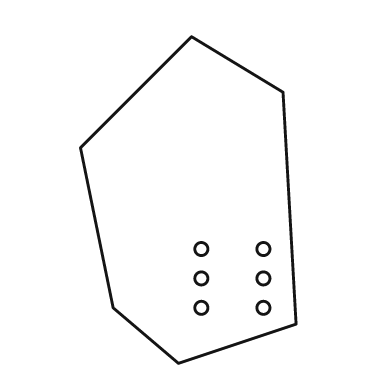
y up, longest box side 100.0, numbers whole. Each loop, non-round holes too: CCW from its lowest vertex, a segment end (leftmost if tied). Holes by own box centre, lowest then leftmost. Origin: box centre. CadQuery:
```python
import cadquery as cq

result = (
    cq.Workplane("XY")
    .moveTo(-3.0, -50.0)
    .lineTo(33.0, -38.0)
    .lineTo(29.0, 33.0)
    .lineTo(1.0, 50.0)
    .lineTo(-33.0, 16.0)
    .lineTo(-23.0, -33.0)
    .close()
    .moveTo(4.0, -33.0)
    .circle(2.0)
    .moveTo(23.0, -33.0)
    .circle(2.0)
    .moveTo(4.0, -24.0)
    .circle(2.0)
    .moveTo(23.0, -24.0)
    .circle(2.0)
    .moveTo(4.0, -15.0)
    .circle(2.0)
    .moveTo(23.0, -15.0)
    .circle(2.0)
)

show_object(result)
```